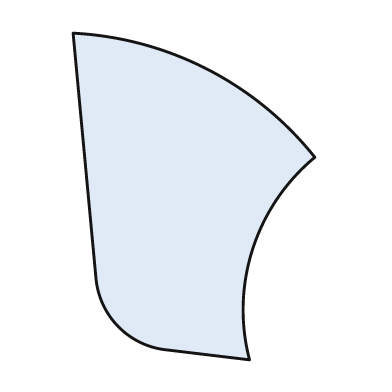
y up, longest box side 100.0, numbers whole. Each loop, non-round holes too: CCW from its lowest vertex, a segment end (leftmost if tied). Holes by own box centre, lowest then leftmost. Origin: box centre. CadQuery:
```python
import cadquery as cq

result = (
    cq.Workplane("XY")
    .moveTo(17.0, -50.0)
    .threePointArc((18.0, -16.0), (37.0, 12.0))
    .threePointArc((4.0, 39.0), (-37.0, 50.0))
    .lineTo(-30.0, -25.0)
    .threePointArc((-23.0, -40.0), (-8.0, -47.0))
    .close()
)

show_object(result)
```